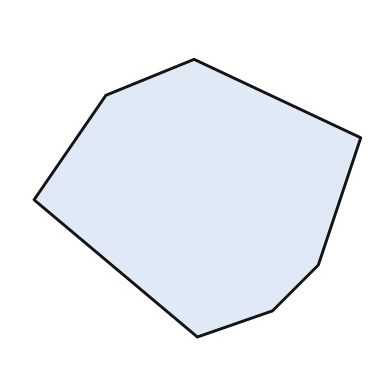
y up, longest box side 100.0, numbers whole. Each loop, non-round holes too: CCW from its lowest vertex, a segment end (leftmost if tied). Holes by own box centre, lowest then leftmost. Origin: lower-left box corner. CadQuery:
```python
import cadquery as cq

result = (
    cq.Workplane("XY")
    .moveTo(50.0, 0.0)
    .lineTo(73.0, 8.0)
    .lineTo(87.0, 22.0)
    .lineTo(100.0, 61.0)
    .lineTo(49.0, 85.0)
    .lineTo(22.0, 74.0)
    .lineTo(0.0, 42.0)
    .close()
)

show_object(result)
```